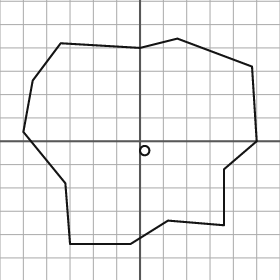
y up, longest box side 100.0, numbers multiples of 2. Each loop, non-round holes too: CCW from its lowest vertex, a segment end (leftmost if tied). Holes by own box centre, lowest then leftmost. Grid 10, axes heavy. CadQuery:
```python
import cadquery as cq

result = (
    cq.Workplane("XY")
    .moveTo(-30.0, -44.0)
    .lineTo(-4.0, -44.0)
    .lineTo(12.0, -34.0)
    .lineTo(36.0, -36.0)
    .lineTo(36.0, -12.0)
    .lineTo(50.0, 0.0)
    .lineTo(48.0, 32.0)
    .lineTo(16.0, 44.0)
    .lineTo(0.0, 40.0)
    .lineTo(-34.0, 42.0)
    .lineTo(-46.0, 26.0)
    .lineTo(-50.0, 4.0)
    .lineTo(-32.0, -18.0)
    .close()
    .moveTo(2.0, -4.0)
    .circle(2.0)
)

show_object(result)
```